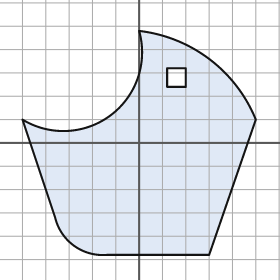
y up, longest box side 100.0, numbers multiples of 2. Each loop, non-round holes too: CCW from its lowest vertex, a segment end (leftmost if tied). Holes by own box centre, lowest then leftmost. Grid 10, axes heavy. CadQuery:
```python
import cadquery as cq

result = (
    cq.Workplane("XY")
    .moveTo(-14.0, -48.0)
    .lineTo(30.0, -48.0)
    .lineTo(50.0, 10.0)
    .threePointArc((30.0, 36.0), (0.0, 48.0))
    .threePointArc((-12.0, 12.0), (-50.0, 10.0))
    .lineTo(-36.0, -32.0)
    .threePointArc((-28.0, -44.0), (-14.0, -48.0))
    .close()
    .moveTo(12.0, 24.0)
    .lineTo(20.0, 24.0)
    .lineTo(20.0, 32.0)
    .lineTo(12.0, 32.0)
    .close()
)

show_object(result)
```